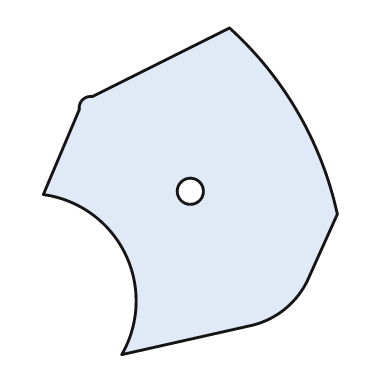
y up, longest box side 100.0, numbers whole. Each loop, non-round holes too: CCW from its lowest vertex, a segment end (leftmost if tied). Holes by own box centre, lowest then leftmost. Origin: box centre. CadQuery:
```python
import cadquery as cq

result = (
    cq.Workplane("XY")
    .moveTo(-21.0, -50.0)
    .lineTo(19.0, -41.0)
    .threePointArc((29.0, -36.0), (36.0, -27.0))
    .lineTo(45.0, -7.0)
    .threePointArc((33.0, 24.0), (12.0, 50.0))
    .lineTo(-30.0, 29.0)
    .threePointArc((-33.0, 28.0), (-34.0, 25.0))
    .lineTo(-45.0, -1.0)
    .threePointArc((-20.0, -19.0), (-21.0, -50.0))
    .close()
    .moveTo(0.0, 0.0)
    .circle(4.0)
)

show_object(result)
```